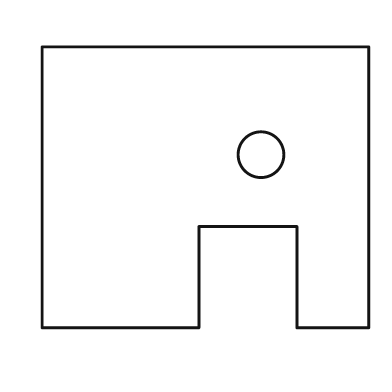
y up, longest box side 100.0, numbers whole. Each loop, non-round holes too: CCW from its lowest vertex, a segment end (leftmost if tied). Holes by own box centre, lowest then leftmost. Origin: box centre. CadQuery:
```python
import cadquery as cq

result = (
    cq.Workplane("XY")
    .moveTo(-50.0, -43.0)
    .lineTo(-2.0, -43.0)
    .lineTo(-2.0, -12.0)
    .lineTo(28.0, -12.0)
    .lineTo(28.0, -43.0)
    .lineTo(50.0, -43.0)
    .lineTo(50.0, 43.0)
    .lineTo(-50.0, 43.0)
    .close()
    .moveTo(17.0, 10.0)
    .circle(7.0)
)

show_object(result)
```